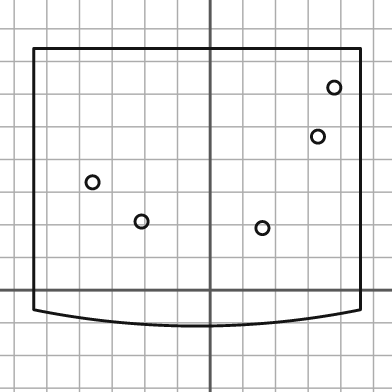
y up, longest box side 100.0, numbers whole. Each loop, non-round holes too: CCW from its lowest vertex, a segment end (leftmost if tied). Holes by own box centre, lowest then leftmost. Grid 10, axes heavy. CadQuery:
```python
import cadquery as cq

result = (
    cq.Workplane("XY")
    .moveTo(-54.0, -6.0)
    .threePointArc((-4.0, -11.0), (46.0, -6.0))
    .lineTo(46.0, 74.0)
    .lineTo(-54.0, 74.0)
    .close()
    .moveTo(16.0, 19.0)
    .circle(2.0)
    .moveTo(-21.0, 21.0)
    .circle(2.0)
    .moveTo(-36.0, 33.0)
    .circle(2.0)
    .moveTo(33.0, 47.0)
    .circle(2.0)
    .moveTo(38.0, 62.0)
    .circle(2.0)
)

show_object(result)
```